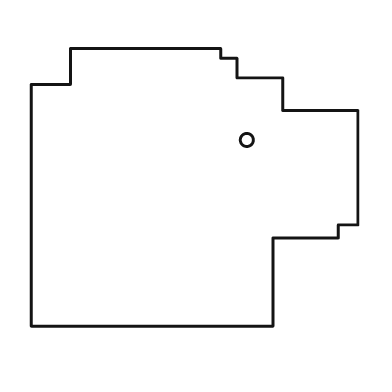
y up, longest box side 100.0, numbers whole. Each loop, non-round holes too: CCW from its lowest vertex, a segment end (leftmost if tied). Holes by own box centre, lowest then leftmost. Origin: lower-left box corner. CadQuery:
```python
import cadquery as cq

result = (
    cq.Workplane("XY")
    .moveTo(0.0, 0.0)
    .lineTo(74.0, 0.0)
    .lineTo(74.0, 27.0)
    .lineTo(94.0, 27.0)
    .lineTo(94.0, 31.0)
    .lineTo(100.0, 31.0)
    .lineTo(100.0, 66.0)
    .lineTo(77.0, 66.0)
    .lineTo(77.0, 76.0)
    .lineTo(63.0, 76.0)
    .lineTo(63.0, 82.0)
    .lineTo(58.0, 82.0)
    .lineTo(58.0, 85.0)
    .lineTo(12.0, 85.0)
    .lineTo(12.0, 74.0)
    .lineTo(0.0, 74.0)
    .close()
    .moveTo(66.0, 57.0)
    .circle(2.0)
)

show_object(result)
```